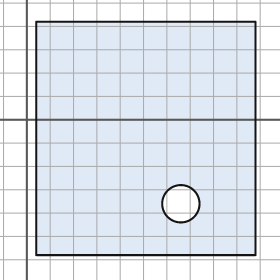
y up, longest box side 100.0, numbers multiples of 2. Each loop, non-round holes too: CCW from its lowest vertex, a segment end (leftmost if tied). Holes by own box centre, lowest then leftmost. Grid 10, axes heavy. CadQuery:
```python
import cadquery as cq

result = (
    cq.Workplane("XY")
    .moveTo(4.0, -58.0)
    .lineTo(98.0, -58.0)
    .lineTo(98.0, 42.0)
    .lineTo(4.0, 42.0)
    .close()
    .moveTo(66.0, -36.0)
    .circle(8.0)
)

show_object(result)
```